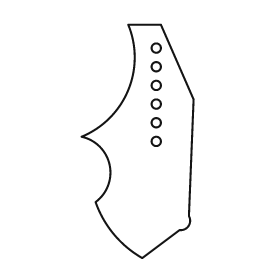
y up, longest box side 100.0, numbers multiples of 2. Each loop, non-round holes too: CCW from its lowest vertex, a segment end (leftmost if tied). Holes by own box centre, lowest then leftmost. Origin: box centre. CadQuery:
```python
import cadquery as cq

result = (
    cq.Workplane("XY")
    .moveTo(2.0, -50.0)
    .lineTo(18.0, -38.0)
    .threePointArc((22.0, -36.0), (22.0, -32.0))
    .lineTo(24.0, 18.0)
    .lineTo(10.0, 50.0)
    .lineTo(-4.0, 50.0)
    .threePointArc((-4.0, 22.0), (-24.0, 2.0))
    .threePointArc((-12.0, -10.0), (-18.0, -26.0))
    .threePointArc((-10.0, -40.0), (2.0, -50.0))
    .close()
    .moveTo(8.0, 0.0)
    .circle(2.0)
    .moveTo(8.0, 8.0)
    .circle(2.0)
    .moveTo(8.0, 16.0)
    .circle(2.0)
    .moveTo(8.0, 24.0)
    .circle(2.0)
    .moveTo(8.0, 32.0)
    .circle(2.0)
    .moveTo(8.0, 40.0)
    .circle(2.0)
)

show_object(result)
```